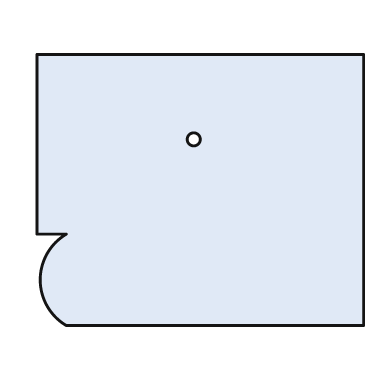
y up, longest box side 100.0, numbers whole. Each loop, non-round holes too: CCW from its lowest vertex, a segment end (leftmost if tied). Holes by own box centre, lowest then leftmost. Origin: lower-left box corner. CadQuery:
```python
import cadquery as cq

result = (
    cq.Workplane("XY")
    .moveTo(9.0, 0.0)
    .lineTo(100.0, 0.0)
    .lineTo(100.0, 83.0)
    .lineTo(0.0, 83.0)
    .lineTo(0.0, 28.0)
    .lineTo(9.0, 28.0)
    .threePointArc((1.0, 14.0), (9.0, 0.0))
    .close()
    .moveTo(48.0, 57.0)
    .circle(2.0)
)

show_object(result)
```